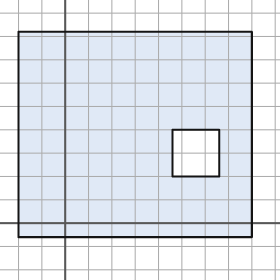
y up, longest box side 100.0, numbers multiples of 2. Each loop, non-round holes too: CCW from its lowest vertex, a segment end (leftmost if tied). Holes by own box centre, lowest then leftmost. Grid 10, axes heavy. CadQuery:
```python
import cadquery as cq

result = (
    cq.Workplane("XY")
    .moveTo(-20.0, -6.0)
    .lineTo(80.0, -6.0)
    .lineTo(80.0, 82.0)
    .lineTo(-20.0, 82.0)
    .close()
    .moveTo(46.0, 20.0)
    .lineTo(66.0, 20.0)
    .lineTo(66.0, 40.0)
    .lineTo(46.0, 40.0)
    .close()
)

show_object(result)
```